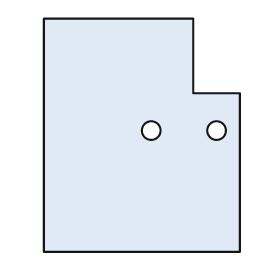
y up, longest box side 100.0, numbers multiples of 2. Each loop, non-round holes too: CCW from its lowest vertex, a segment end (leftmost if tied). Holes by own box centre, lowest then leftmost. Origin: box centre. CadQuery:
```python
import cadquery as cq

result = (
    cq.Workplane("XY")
    .moveTo(-42.0, -50.0)
    .lineTo(42.0, -50.0)
    .lineTo(42.0, 18.0)
    .lineTo(22.0, 18.0)
    .lineTo(22.0, 50.0)
    .lineTo(-42.0, 50.0)
    .close()
    .moveTo(4.0, 2.0)
    .circle(4.0)
    .moveTo(32.0, 2.0)
    .circle(4.0)
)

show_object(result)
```